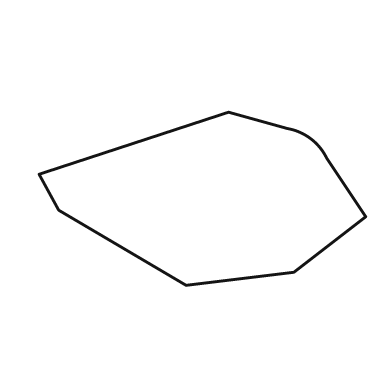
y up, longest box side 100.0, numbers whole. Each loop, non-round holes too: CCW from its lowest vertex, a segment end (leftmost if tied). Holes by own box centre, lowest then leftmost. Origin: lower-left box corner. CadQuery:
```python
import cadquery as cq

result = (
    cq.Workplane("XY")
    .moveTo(45.0, 0.0)
    .lineTo(78.0, 4.0)
    .lineTo(100.0, 21.0)
    .lineTo(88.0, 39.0)
    .threePointArc((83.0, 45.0), (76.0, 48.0))
    .lineTo(58.0, 53.0)
    .lineTo(0.0, 34.0)
    .lineTo(6.0, 23.0)
    .close()
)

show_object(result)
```